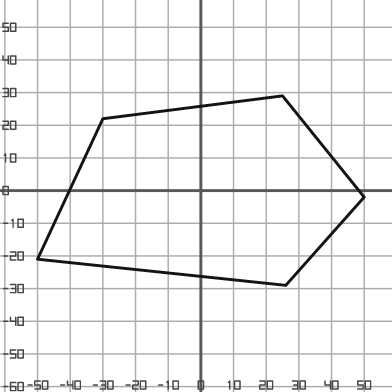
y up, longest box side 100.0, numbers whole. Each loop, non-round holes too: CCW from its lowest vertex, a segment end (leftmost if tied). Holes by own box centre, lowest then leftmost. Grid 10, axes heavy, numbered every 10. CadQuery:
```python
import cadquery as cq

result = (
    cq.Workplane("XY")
    .moveTo(26.0, -29.0)
    .lineTo(50.0, -2.0)
    .lineTo(25.0, 29.0)
    .lineTo(-30.0, 22.0)
    .lineTo(-50.0, -21.0)
    .close()
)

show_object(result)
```